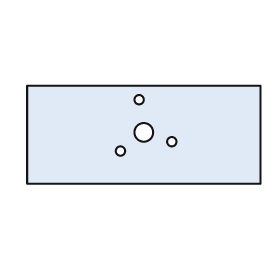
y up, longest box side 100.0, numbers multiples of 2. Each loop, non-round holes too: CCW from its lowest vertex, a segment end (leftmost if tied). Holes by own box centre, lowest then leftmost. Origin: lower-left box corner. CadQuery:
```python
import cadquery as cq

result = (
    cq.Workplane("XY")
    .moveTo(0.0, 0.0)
    .lineTo(100.0, 0.0)
    .lineTo(100.0, 42.0)
    .lineTo(0.0, 42.0)
    .close()
    .moveTo(40.0, 14.0)
    .circle(2.0)
    .moveTo(62.0, 18.0)
    .circle(2.0)
    .moveTo(50.0, 22.0)
    .circle(4.0)
    .moveTo(48.0, 36.0)
    .circle(2.0)
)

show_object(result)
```